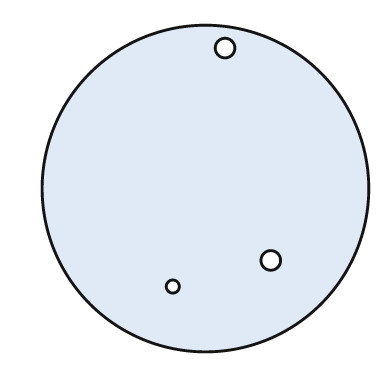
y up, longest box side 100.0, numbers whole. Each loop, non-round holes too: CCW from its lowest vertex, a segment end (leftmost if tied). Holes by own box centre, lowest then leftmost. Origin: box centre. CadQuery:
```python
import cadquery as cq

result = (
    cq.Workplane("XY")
    .moveTo(0.0, 0.0)
    .circle(50.0)
    .moveTo(-10.0, -30.0)
    .circle(2.0)
    .moveTo(20.0, -22.0)
    .circle(3.0)
    .moveTo(6.0, 43.0)
    .circle(3.0)
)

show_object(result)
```